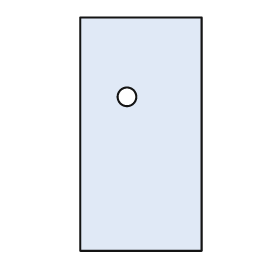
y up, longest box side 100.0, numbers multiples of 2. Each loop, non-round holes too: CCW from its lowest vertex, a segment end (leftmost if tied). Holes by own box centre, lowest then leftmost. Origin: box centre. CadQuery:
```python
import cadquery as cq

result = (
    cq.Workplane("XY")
    .moveTo(-26.0, -50.0)
    .lineTo(26.0, -50.0)
    .lineTo(26.0, 50.0)
    .lineTo(-26.0, 50.0)
    .close()
    .moveTo(-6.0, 16.0)
    .circle(4.0)
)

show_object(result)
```